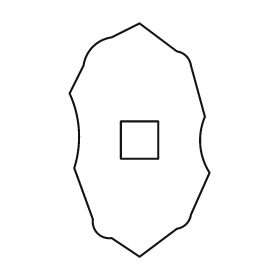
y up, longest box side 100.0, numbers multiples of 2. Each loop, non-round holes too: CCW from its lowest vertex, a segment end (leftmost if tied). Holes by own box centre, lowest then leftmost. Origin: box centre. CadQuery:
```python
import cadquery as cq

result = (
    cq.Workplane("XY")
    .moveTo(0.0, -50.0)
    .lineTo(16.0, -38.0)
    .threePointArc((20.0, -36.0), (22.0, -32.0))
    .lineTo(30.0, -14.0)
    .threePointArc((26.0, -2.0), (28.0, 10.0))
    .lineTo(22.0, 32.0)
    .threePointArc((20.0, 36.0), (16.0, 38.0))
    .lineTo(0.0, 50.0)
    .lineTo(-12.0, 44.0)
    .threePointArc((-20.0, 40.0), (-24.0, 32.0))
    .lineTo(-30.0, 20.0)
    .threePointArc((-26.0, 4.0), (-28.0, -12.0))
    .lineTo(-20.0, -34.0)
    .threePointArc((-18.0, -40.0), (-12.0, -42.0))
    .close()
    .moveTo(-8.0, -8.0)
    .lineTo(8.0, -8.0)
    .lineTo(8.0, 8.0)
    .lineTo(-8.0, 8.0)
    .close()
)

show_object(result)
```